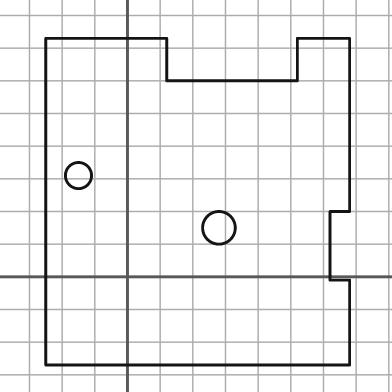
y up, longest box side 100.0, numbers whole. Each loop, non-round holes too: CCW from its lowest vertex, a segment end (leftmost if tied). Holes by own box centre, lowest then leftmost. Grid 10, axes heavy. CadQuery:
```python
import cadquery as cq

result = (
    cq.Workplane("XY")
    .moveTo(-25.0, -27.0)
    .lineTo(68.0, -27.0)
    .lineTo(68.0, -1.0)
    .lineTo(62.0, -1.0)
    .lineTo(62.0, 20.0)
    .lineTo(68.0, 20.0)
    .lineTo(68.0, 73.0)
    .lineTo(52.0, 73.0)
    .lineTo(52.0, 60.0)
    .lineTo(12.0, 60.0)
    .lineTo(12.0, 73.0)
    .lineTo(-25.0, 73.0)
    .close()
    .moveTo(28.0, 15.0)
    .circle(5.0)
    .moveTo(-15.0, 31.0)
    .circle(4.0)
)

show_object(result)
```